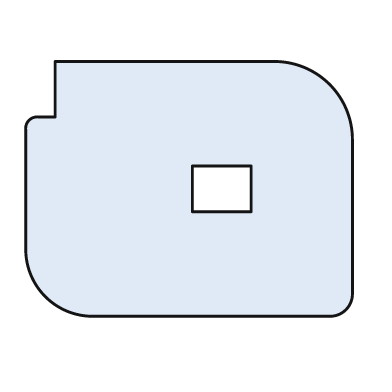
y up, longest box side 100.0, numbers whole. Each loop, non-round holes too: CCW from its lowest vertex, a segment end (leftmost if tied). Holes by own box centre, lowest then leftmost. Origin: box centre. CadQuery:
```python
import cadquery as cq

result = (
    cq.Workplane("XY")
    .moveTo(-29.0, -39.0)
    .lineTo(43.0, -39.0)
    .threePointArc((48.0, -37.0), (50.0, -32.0))
    .lineTo(50.0, 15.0)
    .threePointArc((43.0, 32.0), (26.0, 39.0))
    .lineTo(-41.0, 39.0)
    .lineTo(-41.0, 22.0)
    .lineTo(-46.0, 22.0)
    .threePointArc((-49.0, 21.0), (-50.0, 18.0))
    .lineTo(-50.0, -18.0)
    .threePointArc((-44.0, -33.0), (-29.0, -39.0))
    .close()
    .moveTo(1.0, -7.0)
    .lineTo(19.0, -7.0)
    .lineTo(19.0, 7.0)
    .lineTo(1.0, 7.0)
    .close()
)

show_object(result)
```